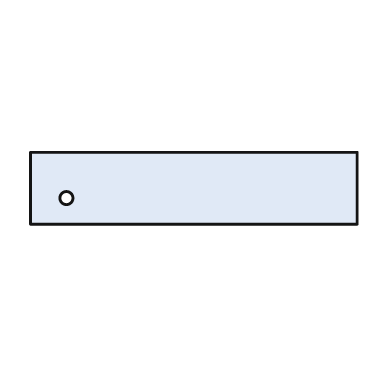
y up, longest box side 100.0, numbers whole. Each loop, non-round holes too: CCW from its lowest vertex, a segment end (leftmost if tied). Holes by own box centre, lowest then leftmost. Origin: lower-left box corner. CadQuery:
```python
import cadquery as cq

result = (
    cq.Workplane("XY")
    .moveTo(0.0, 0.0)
    .lineTo(100.0, 0.0)
    .lineTo(100.0, 22.0)
    .lineTo(0.0, 22.0)
    .close()
    .moveTo(11.0, 8.0)
    .circle(2.0)
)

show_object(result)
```